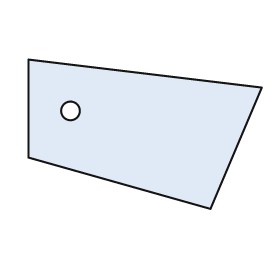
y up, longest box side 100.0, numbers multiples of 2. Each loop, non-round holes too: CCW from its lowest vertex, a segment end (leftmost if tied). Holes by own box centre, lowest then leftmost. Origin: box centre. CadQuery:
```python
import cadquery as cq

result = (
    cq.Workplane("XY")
    .moveTo(28.0, -32.0)
    .lineTo(50.0, 20.0)
    .lineTo(-50.0, 32.0)
    .lineTo(-50.0, -10.0)
    .close()
    .moveTo(-32.0, 10.0)
    .circle(4.0)
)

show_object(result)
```